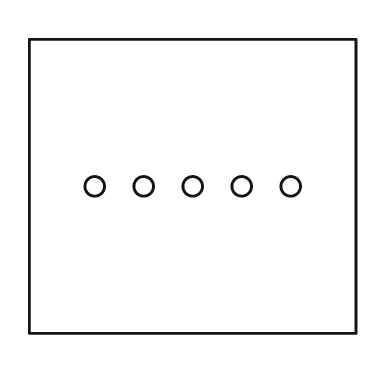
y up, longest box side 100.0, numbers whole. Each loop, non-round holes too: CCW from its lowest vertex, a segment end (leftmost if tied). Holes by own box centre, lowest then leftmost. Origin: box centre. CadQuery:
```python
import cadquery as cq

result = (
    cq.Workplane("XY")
    .moveTo(-50.0, -45.0)
    .lineTo(50.0, -45.0)
    .lineTo(50.0, 45.0)
    .lineTo(-50.0, 45.0)
    .close()
    .moveTo(-30.0, 0.0)
    .circle(3.0)
    .moveTo(-15.0, 0.0)
    .circle(3.0)
    .moveTo(0.0, 0.0)
    .circle(3.0)
    .moveTo(15.0, 0.0)
    .circle(3.0)
    .moveTo(30.0, 0.0)
    .circle(3.0)
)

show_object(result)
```